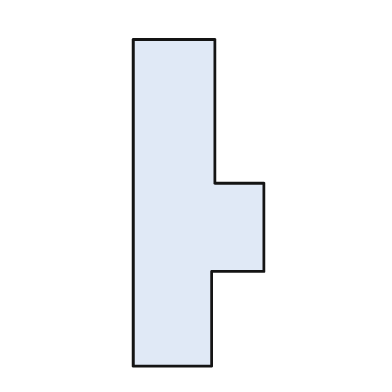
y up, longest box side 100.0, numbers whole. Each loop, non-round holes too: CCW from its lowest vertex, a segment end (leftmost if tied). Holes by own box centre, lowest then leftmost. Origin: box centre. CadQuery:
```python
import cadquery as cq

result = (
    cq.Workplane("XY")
    .moveTo(-20.0, -50.0)
    .lineTo(4.0, -50.0)
    .lineTo(4.0, -21.0)
    .lineTo(20.0, -21.0)
    .lineTo(20.0, 6.0)
    .lineTo(5.0, 6.0)
    .lineTo(5.0, 50.0)
    .lineTo(-20.0, 50.0)
    .close()
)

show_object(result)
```